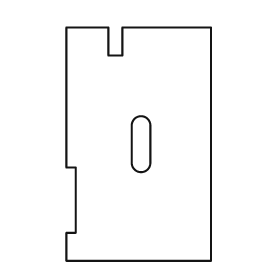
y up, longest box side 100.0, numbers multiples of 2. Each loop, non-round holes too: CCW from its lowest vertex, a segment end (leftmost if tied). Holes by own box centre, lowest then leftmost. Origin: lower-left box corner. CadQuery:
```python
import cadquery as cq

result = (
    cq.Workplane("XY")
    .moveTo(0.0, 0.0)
    .lineTo(62.0, 0.0)
    .lineTo(62.0, 100.0)
    .lineTo(24.0, 100.0)
    .lineTo(24.0, 88.0)
    .lineTo(18.0, 88.0)
    .lineTo(18.0, 100.0)
    .lineTo(0.0, 100.0)
    .lineTo(0.0, 40.0)
    .lineTo(4.0, 40.0)
    .lineTo(4.0, 12.0)
    .lineTo(0.0, 12.0)
    .close()
    .moveTo(28.0, 42.0)
    .threePointArc((32.0, 38.0), (36.0, 42.0))
    .lineTo(36.0, 58.0)
    .threePointArc((32.0, 62.0), (28.0, 58.0))
    .close()
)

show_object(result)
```